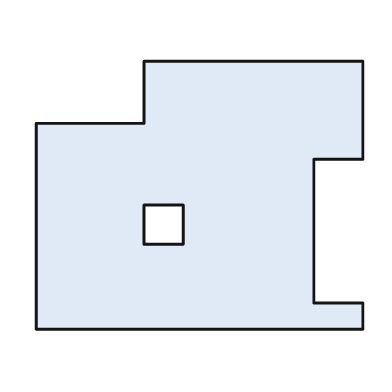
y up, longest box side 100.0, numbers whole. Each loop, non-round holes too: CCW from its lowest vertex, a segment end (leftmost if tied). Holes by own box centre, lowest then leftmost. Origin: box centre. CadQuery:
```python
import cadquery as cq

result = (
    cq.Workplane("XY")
    .moveTo(-50.0, -41.0)
    .lineTo(50.0, -41.0)
    .lineTo(50.0, -33.0)
    .lineTo(35.0, -33.0)
    .lineTo(35.0, 11.0)
    .lineTo(50.0, 11.0)
    .lineTo(50.0, 41.0)
    .lineTo(-17.0, 41.0)
    .lineTo(-17.0, 22.0)
    .lineTo(-50.0, 22.0)
    .close()
    .moveTo(-17.0, -15.0)
    .lineTo(-5.0, -15.0)
    .lineTo(-5.0, -3.0)
    .lineTo(-17.0, -3.0)
    .close()
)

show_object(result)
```